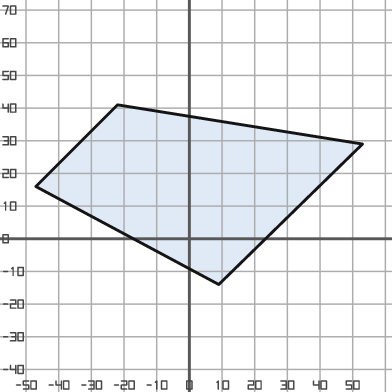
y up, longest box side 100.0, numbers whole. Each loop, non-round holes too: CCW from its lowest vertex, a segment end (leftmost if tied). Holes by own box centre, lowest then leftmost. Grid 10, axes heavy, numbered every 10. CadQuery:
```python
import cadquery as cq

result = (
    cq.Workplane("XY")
    .moveTo(9.0, -14.0)
    .lineTo(53.0, 29.0)
    .lineTo(-22.0, 41.0)
    .lineTo(-47.0, 16.0)
    .close()
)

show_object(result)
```